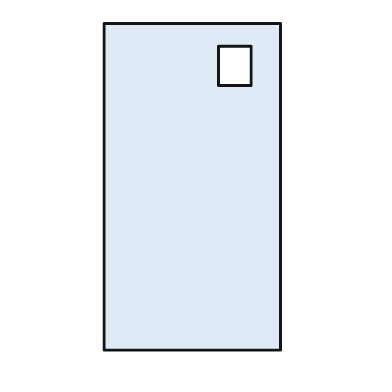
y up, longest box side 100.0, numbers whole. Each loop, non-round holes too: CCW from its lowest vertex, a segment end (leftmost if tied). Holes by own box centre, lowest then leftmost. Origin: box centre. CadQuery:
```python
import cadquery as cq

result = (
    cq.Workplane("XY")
    .moveTo(-27.0, -50.0)
    .lineTo(27.0, -50.0)
    .lineTo(27.0, 50.0)
    .lineTo(-27.0, 50.0)
    .close()
    .moveTo(8.0, 31.0)
    .lineTo(18.0, 31.0)
    .lineTo(18.0, 43.0)
    .lineTo(8.0, 43.0)
    .close()
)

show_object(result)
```